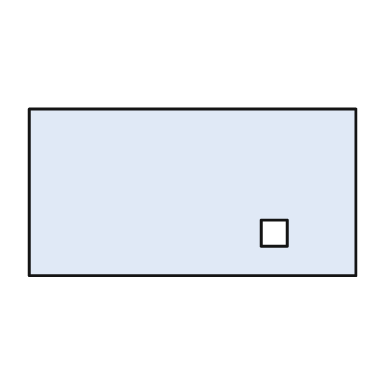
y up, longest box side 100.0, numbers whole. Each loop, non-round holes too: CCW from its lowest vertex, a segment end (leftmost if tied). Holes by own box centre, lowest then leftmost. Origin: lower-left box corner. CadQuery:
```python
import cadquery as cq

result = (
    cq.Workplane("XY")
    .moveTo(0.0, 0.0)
    .lineTo(100.0, 0.0)
    .lineTo(100.0, 51.0)
    .lineTo(0.0, 51.0)
    .close()
    .moveTo(71.0, 9.0)
    .lineTo(79.0, 9.0)
    .lineTo(79.0, 17.0)
    .lineTo(71.0, 17.0)
    .close()
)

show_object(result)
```